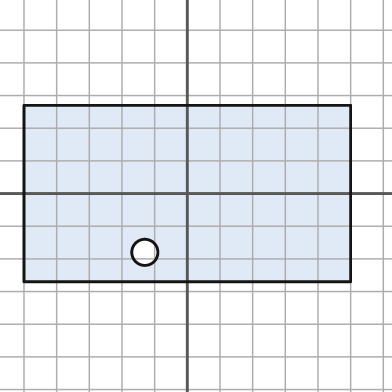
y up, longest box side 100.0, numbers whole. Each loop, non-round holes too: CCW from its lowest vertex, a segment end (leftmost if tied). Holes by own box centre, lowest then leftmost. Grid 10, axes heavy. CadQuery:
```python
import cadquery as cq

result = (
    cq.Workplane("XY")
    .moveTo(-50.0, -27.0)
    .lineTo(50.0, -27.0)
    .lineTo(50.0, 27.0)
    .lineTo(-50.0, 27.0)
    .close()
    .moveTo(-13.0, -18.0)
    .circle(4.0)
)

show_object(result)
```